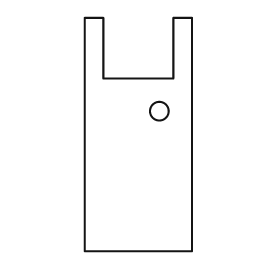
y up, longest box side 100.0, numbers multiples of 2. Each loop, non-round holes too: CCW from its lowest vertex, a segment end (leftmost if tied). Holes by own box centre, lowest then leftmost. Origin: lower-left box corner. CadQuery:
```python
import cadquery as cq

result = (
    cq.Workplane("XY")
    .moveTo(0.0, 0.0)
    .lineTo(46.0, 0.0)
    .lineTo(46.0, 100.0)
    .lineTo(38.0, 100.0)
    .lineTo(38.0, 74.0)
    .lineTo(8.0, 74.0)
    .lineTo(8.0, 100.0)
    .lineTo(0.0, 100.0)
    .close()
    .moveTo(32.0, 60.0)
    .circle(4.0)
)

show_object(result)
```